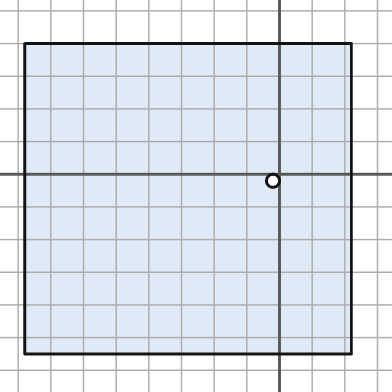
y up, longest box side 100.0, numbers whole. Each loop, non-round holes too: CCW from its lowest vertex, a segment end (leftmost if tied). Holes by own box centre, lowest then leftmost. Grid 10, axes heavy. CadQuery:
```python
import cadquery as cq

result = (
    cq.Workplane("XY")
    .moveTo(-78.0, -55.0)
    .lineTo(22.0, -55.0)
    .lineTo(22.0, 40.0)
    .lineTo(-78.0, 40.0)
    .close()
    .moveTo(-2.0, -2.0)
    .circle(2.0)
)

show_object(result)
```